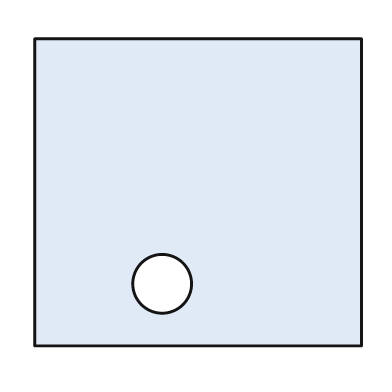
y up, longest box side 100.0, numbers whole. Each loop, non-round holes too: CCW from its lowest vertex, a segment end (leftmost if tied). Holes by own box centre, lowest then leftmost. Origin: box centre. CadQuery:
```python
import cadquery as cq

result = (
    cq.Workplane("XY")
    .moveTo(-50.0, -47.0)
    .lineTo(50.0, -47.0)
    .lineTo(50.0, 47.0)
    .lineTo(-50.0, 47.0)
    .close()
    .moveTo(-11.0, -28.0)
    .circle(9.0)
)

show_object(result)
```